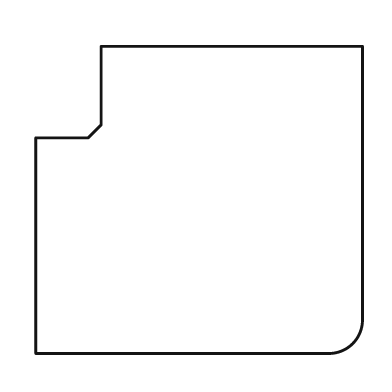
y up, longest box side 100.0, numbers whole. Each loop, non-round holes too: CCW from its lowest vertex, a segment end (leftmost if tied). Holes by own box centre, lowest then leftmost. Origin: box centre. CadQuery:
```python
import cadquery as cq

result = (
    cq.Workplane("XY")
    .moveTo(-50.0, -47.0)
    .lineTo(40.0, -47.0)
    .threePointArc((47.0, -44.0), (50.0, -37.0))
    .lineTo(50.0, 47.0)
    .lineTo(-30.0, 47.0)
    .lineTo(-30.0, 23.0)
    .lineTo(-34.0, 19.0)
    .lineTo(-50.0, 19.0)
    .close()
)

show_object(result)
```